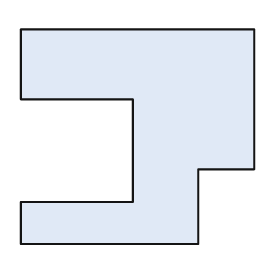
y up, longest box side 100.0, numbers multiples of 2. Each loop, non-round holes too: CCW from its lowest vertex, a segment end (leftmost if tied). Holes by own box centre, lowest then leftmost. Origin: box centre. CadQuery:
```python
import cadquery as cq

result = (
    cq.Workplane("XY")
    .moveTo(-50.0, -46.0)
    .lineTo(26.0, -46.0)
    .lineTo(26.0, -14.0)
    .lineTo(50.0, -14.0)
    .lineTo(50.0, 46.0)
    .lineTo(-50.0, 46.0)
    .lineTo(-50.0, 16.0)
    .lineTo(-2.0, 16.0)
    .lineTo(-2.0, -28.0)
    .lineTo(-50.0, -28.0)
    .close()
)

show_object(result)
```